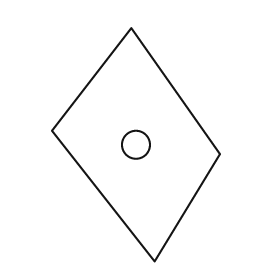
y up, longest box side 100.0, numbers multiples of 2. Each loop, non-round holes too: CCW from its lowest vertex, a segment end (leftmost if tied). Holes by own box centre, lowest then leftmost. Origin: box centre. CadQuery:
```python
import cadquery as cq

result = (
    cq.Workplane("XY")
    .moveTo(8.0, -50.0)
    .lineTo(36.0, -4.0)
    .lineTo(-2.0, 50.0)
    .lineTo(-36.0, 6.0)
    .close()
    .moveTo(0.0, 0.0)
    .circle(6.0)
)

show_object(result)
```